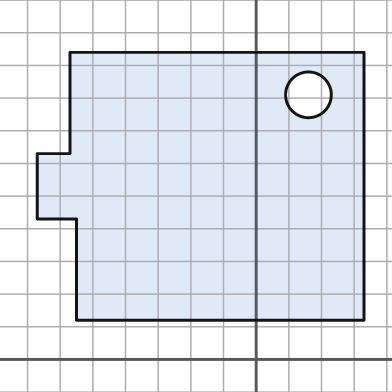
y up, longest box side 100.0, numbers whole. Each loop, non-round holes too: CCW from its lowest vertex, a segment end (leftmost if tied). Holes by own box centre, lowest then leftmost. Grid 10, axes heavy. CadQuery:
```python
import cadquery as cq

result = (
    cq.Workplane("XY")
    .moveTo(-55.0, 12.0)
    .lineTo(33.0, 12.0)
    .lineTo(33.0, 94.0)
    .lineTo(-57.0, 94.0)
    .lineTo(-57.0, 63.0)
    .lineTo(-67.0, 63.0)
    .lineTo(-67.0, 43.0)
    .lineTo(-55.0, 43.0)
    .close()
    .moveTo(16.0, 81.0)
    .circle(7.0)
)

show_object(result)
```